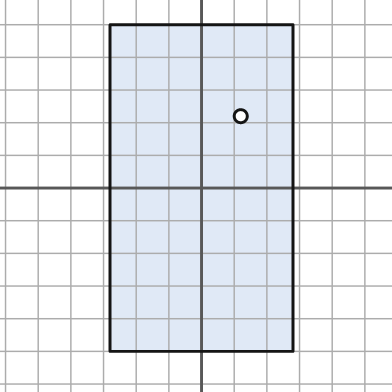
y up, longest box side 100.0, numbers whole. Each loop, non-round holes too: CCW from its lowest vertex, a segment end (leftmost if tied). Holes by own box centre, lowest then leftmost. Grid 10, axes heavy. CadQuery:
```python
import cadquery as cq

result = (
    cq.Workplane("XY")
    .moveTo(-28.0, -50.0)
    .lineTo(28.0, -50.0)
    .lineTo(28.0, 50.0)
    .lineTo(-28.0, 50.0)
    .close()
    .moveTo(12.0, 22.0)
    .circle(2.0)
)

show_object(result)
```